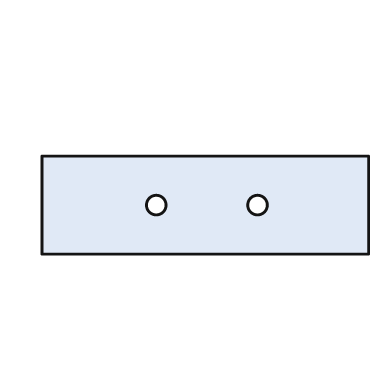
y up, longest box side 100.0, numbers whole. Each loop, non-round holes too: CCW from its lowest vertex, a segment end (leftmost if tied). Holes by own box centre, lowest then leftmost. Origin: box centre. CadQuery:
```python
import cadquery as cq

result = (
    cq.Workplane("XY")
    .moveTo(-50.0, -15.0)
    .lineTo(50.0, -15.0)
    .lineTo(50.0, 15.0)
    .lineTo(-50.0, 15.0)
    .close()
    .moveTo(-15.0, 0.0)
    .circle(3.0)
    .moveTo(16.0, 0.0)
    .circle(3.0)
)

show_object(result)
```